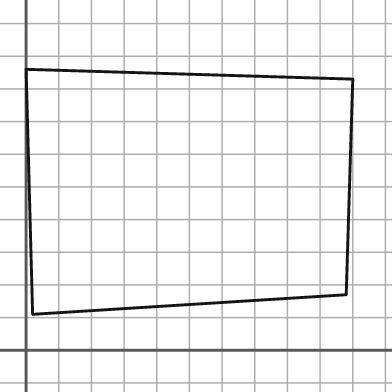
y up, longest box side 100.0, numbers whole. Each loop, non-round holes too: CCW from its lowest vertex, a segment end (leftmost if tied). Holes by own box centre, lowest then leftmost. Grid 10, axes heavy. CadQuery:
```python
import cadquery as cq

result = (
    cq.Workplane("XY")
    .moveTo(2.0, 11.0)
    .lineTo(98.0, 17.0)
    .lineTo(100.0, 83.0)
    .lineTo(0.0, 86.0)
    .close()
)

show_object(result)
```